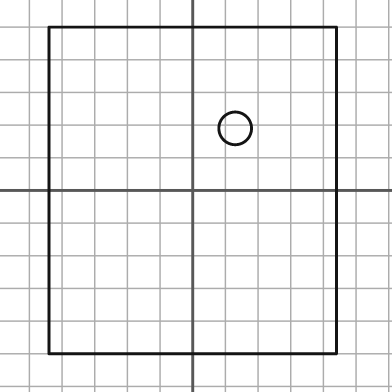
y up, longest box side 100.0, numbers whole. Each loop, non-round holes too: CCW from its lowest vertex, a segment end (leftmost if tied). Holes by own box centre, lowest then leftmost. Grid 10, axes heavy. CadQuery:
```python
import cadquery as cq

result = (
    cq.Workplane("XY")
    .moveTo(-44.0, -50.0)
    .lineTo(44.0, -50.0)
    .lineTo(44.0, 50.0)
    .lineTo(-44.0, 50.0)
    .close()
    .moveTo(13.0, 19.0)
    .circle(5.0)
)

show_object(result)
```